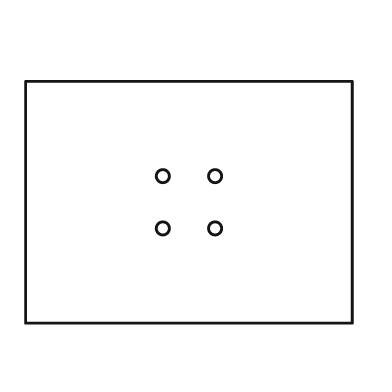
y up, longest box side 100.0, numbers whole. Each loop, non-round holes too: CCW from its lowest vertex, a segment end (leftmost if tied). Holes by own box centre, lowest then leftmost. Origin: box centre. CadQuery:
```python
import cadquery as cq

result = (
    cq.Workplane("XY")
    .moveTo(-50.0, -37.0)
    .lineTo(50.0, -37.0)
    .lineTo(50.0, 37.0)
    .lineTo(-50.0, 37.0)
    .close()
    .moveTo(-8.0, -8.0)
    .circle(2.0)
    .moveTo(8.0, -8.0)
    .circle(2.0)
    .moveTo(-8.0, 8.0)
    .circle(2.0)
    .moveTo(8.0, 8.0)
    .circle(2.0)
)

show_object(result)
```